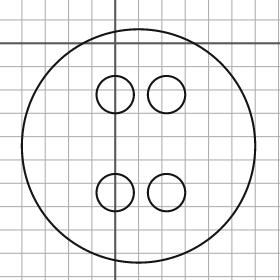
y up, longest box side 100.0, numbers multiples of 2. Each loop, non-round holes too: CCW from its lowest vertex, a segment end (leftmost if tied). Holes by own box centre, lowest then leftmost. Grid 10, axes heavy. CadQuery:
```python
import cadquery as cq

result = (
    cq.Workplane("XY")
    .moveTo(10.0, -44.0)
    .circle(50.0)
    .moveTo(0.0, -64.0)
    .circle(8.0)
    .moveTo(22.0, -64.0)
    .circle(8.0)
    .moveTo(0.0, -22.0)
    .circle(8.0)
    .moveTo(22.0, -22.0)
    .circle(8.0)
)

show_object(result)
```